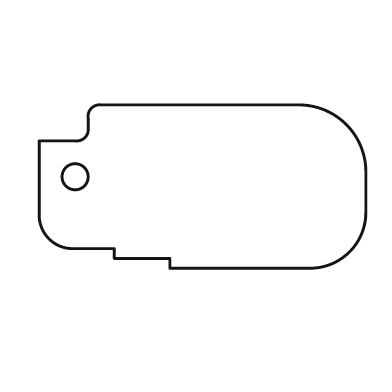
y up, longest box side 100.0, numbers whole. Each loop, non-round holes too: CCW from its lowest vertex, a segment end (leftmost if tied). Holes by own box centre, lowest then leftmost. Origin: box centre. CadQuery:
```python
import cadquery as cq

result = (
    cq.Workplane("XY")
    .moveTo(-10.0, -25.0)
    .lineTo(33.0, -25.0)
    .threePointArc((45.0, -20.0), (50.0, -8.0))
    .lineTo(50.0, 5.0)
    .threePointArc((44.0, 19.0), (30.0, 25.0))
    .lineTo(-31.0, 25.0)
    .threePointArc((-34.0, 24.0), (-35.0, 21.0))
    .lineTo(-35.0, 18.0)
    .threePointArc((-36.0, 15.0), (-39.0, 14.0))
    .lineTo(-50.0, 14.0)
    .lineTo(-50.0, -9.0)
    .threePointArc((-47.0, -16.0), (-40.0, -19.0))
    .lineTo(-27.0, -19.0)
    .lineTo(-27.0, -22.0)
    .lineTo(-10.0, -22.0)
    .close()
    .moveTo(-39.0, 3.0)
    .circle(4.0)
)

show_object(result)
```